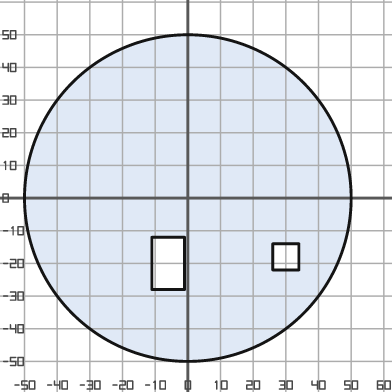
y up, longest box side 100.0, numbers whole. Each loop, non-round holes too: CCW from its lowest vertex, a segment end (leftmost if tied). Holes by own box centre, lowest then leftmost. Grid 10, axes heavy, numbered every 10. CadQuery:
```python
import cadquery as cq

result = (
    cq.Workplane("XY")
    .moveTo(0.0, 0.0)
    .circle(50.0)
    .moveTo(-11.0, -28.0)
    .lineTo(-1.0, -28.0)
    .lineTo(-1.0, -12.0)
    .lineTo(-11.0, -12.0)
    .close()
    .moveTo(26.0, -22.0)
    .lineTo(34.0, -22.0)
    .lineTo(34.0, -14.0)
    .lineTo(26.0, -14.0)
    .close()
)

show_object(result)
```